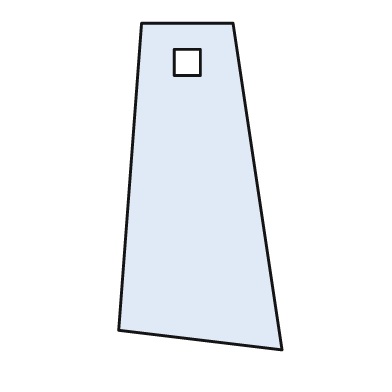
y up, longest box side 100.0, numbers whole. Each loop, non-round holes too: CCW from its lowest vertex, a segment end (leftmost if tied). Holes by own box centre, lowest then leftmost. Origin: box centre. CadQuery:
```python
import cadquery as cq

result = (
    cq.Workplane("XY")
    .moveTo(25.0, -50.0)
    .lineTo(10.0, 50.0)
    .lineTo(-18.0, 50.0)
    .lineTo(-25.0, -44.0)
    .close()
    .moveTo(-8.0, 34.0)
    .lineTo(0.0, 34.0)
    .lineTo(0.0, 42.0)
    .lineTo(-8.0, 42.0)
    .close()
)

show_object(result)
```